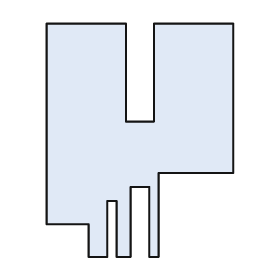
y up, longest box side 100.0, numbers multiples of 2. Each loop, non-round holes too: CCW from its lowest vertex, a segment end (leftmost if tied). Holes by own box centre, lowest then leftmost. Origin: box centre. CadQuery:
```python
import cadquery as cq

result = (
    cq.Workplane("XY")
    .moveTo(-22.0, -50.0)
    .lineTo(-14.0, -50.0)
    .lineTo(-14.0, -26.0)
    .lineTo(-10.0, -26.0)
    .lineTo(-10.0, -50.0)
    .lineTo(-4.0, -50.0)
    .lineTo(-4.0, -20.0)
    .lineTo(4.0, -20.0)
    .lineTo(4.0, -50.0)
    .lineTo(8.0, -50.0)
    .lineTo(8.0, -14.0)
    .lineTo(40.0, -14.0)
    .lineTo(40.0, 50.0)
    .lineTo(6.0, 50.0)
    .lineTo(6.0, 8.0)
    .lineTo(-6.0, 8.0)
    .lineTo(-6.0, 50.0)
    .lineTo(-40.0, 50.0)
    .lineTo(-40.0, -36.0)
    .lineTo(-22.0, -36.0)
    .close()
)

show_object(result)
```